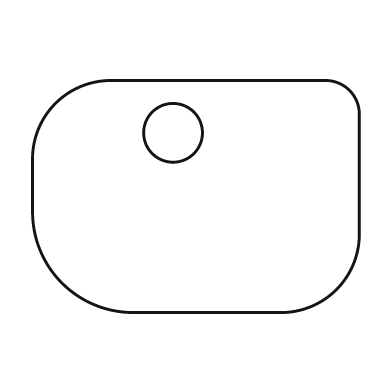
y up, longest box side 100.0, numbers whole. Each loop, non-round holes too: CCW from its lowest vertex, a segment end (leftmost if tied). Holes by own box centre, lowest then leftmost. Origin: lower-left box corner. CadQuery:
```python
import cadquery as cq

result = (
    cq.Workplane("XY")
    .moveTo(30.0, 0.0)
    .lineTo(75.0, 0.0)
    .threePointArc((93.0, 7.0), (100.0, 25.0))
    .lineTo(100.0, 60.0)
    .threePointArc((97.0, 68.0), (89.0, 71.0))
    .lineTo(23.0, 71.0)
    .threePointArc((7.0, 64.0), (0.0, 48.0))
    .lineTo(0.0, 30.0)
    .threePointArc((9.0, 9.0), (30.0, 0.0))
    .close()
    .moveTo(43.0, 55.0)
    .circle(9.0)
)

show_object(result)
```